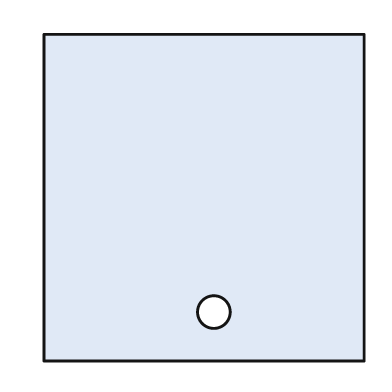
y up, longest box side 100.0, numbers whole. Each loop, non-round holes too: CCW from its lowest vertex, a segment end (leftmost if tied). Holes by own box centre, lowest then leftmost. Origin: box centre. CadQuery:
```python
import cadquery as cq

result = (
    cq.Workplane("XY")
    .moveTo(-49.0, -50.0)
    .lineTo(49.0, -50.0)
    .lineTo(49.0, 50.0)
    .lineTo(-49.0, 50.0)
    .close()
    .moveTo(3.0, -35.0)
    .circle(5.0)
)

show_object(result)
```